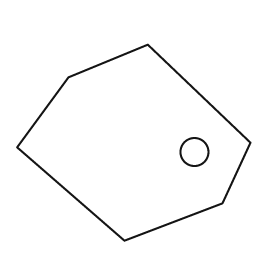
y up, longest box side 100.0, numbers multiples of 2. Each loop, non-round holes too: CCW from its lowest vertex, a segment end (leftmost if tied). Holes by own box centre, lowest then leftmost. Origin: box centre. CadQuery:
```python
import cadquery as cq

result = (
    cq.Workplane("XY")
    .moveTo(-4.0, -42.0)
    .lineTo(38.0, -26.0)
    .lineTo(50.0, 0.0)
    .lineTo(6.0, 42.0)
    .lineTo(-28.0, 28.0)
    .lineTo(-50.0, -2.0)
    .close()
    .moveTo(26.0, -4.0)
    .circle(6.0)
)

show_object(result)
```